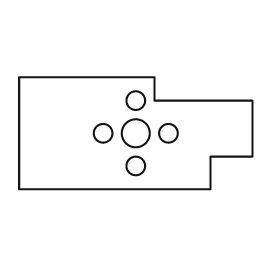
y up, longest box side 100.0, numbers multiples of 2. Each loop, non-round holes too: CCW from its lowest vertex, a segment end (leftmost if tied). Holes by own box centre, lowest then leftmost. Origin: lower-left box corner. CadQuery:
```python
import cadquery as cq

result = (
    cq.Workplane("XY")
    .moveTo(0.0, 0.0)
    .lineTo(82.0, 0.0)
    .lineTo(82.0, 14.0)
    .lineTo(100.0, 14.0)
    .lineTo(100.0, 38.0)
    .lineTo(58.0, 38.0)
    .lineTo(58.0, 48.0)
    .lineTo(0.0, 48.0)
    .close()
    .moveTo(50.0, 10.0)
    .circle(4.0)
    .moveTo(36.0, 24.0)
    .circle(4.0)
    .moveTo(50.0, 24.0)
    .circle(6.0)
    .moveTo(64.0, 24.0)
    .circle(4.0)
    .moveTo(50.0, 38.0)
    .circle(4.0)
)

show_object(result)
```